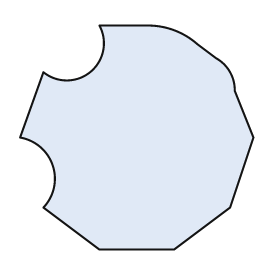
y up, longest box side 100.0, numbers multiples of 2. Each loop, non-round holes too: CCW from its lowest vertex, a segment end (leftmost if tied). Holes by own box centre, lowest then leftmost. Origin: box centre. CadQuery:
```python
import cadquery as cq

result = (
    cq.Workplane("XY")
    .moveTo(-16.0, -48.0)
    .lineTo(16.0, -48.0)
    .lineTo(40.0, -30.0)
    .lineTo(50.0, 0.0)
    .lineTo(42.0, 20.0)
    .threePointArc((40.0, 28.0), (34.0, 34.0))
    .lineTo(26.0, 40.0)
    .threePointArc((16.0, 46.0), (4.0, 48.0))
    .lineTo(-16.0, 48.0)
    .threePointArc((-20.0, 28.0), (-40.0, 28.0))
    .lineTo(-50.0, 0.0)
    .threePointArc((-36.0, -12.0), (-40.0, -30.0))
    .close()
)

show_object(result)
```